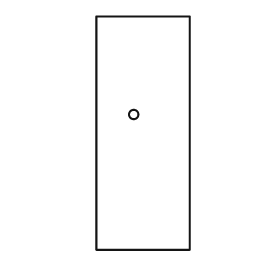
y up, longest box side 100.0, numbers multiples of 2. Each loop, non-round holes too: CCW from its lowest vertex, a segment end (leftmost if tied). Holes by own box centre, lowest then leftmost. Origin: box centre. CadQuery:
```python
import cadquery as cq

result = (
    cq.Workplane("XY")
    .moveTo(-20.0, -50.0)
    .lineTo(20.0, -50.0)
    .lineTo(20.0, 50.0)
    .lineTo(-20.0, 50.0)
    .close()
    .moveTo(-4.0, 8.0)
    .circle(2.0)
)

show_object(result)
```